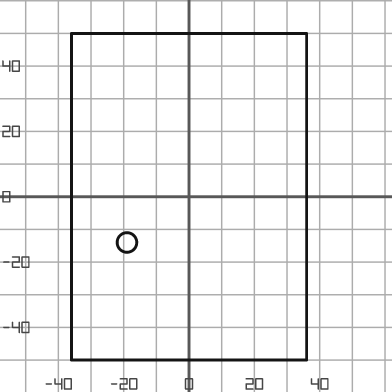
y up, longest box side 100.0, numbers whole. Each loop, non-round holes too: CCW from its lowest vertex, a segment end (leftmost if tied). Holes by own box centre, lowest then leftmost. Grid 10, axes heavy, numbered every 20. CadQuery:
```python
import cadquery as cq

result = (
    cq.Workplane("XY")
    .moveTo(-36.0, -50.0)
    .lineTo(36.0, -50.0)
    .lineTo(36.0, 50.0)
    .lineTo(-36.0, 50.0)
    .close()
    .moveTo(-19.0, -14.0)
    .circle(3.0)
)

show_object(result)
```